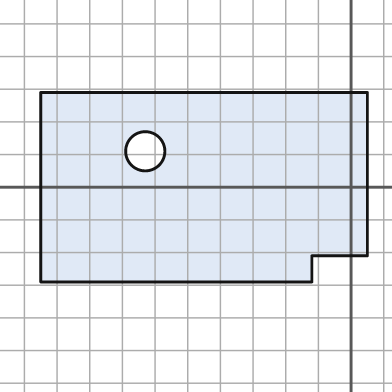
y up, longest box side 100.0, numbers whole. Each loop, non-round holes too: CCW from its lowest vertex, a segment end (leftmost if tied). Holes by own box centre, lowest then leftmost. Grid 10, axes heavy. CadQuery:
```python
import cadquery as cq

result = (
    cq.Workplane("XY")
    .moveTo(-95.0, -29.0)
    .lineTo(-12.0, -29.0)
    .lineTo(-12.0, -21.0)
    .lineTo(5.0, -21.0)
    .lineTo(5.0, 29.0)
    .lineTo(-95.0, 29.0)
    .close()
    .moveTo(-63.0, 11.0)
    .circle(6.0)
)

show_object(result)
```